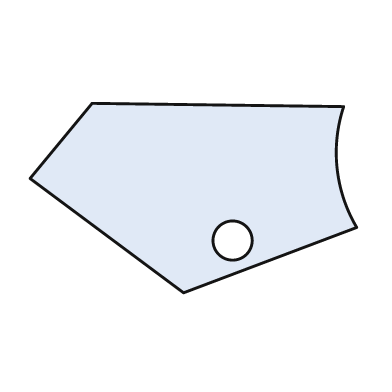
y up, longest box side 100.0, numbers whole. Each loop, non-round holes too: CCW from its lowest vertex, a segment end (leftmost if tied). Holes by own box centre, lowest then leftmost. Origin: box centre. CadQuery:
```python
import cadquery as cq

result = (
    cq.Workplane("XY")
    .moveTo(-3.0, -29.0)
    .lineTo(50.0, -9.0)
    .threePointArc((44.0, 9.0), (46.0, 28.0))
    .lineTo(-31.0, 29.0)
    .lineTo(-50.0, 6.0)
    .close()
    .moveTo(12.0, -13.0)
    .circle(6.0)
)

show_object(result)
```